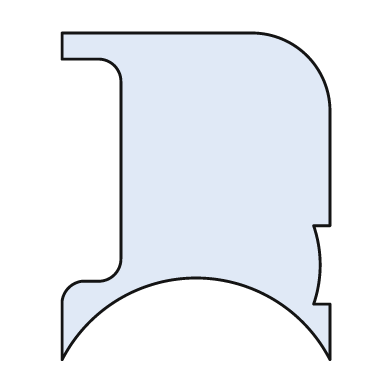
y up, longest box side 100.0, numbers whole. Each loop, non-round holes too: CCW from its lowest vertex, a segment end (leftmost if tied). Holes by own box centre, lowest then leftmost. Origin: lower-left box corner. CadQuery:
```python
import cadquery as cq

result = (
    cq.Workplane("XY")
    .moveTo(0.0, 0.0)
    .threePointArc((41.0, 25.0), (82.0, 0.0))
    .lineTo(82.0, 17.0)
    .lineTo(77.0, 17.0)
    .threePointArc((79.0, 29.0), (77.0, 41.0))
    .lineTo(82.0, 41.0)
    .lineTo(82.0, 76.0)
    .threePointArc((75.0, 93.0), (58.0, 100.0))
    .lineTo(0.0, 100.0)
    .lineTo(0.0, 92.0)
    .lineTo(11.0, 92.0)
    .threePointArc((16.0, 90.0), (18.0, 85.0))
    .lineTo(18.0, 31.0)
    .threePointArc((16.0, 26.0), (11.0, 24.0))
    .lineTo(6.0, 24.0)
    .threePointArc((2.0, 22.0), (0.0, 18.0))
    .close()
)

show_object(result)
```